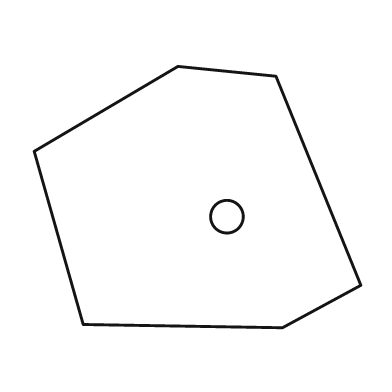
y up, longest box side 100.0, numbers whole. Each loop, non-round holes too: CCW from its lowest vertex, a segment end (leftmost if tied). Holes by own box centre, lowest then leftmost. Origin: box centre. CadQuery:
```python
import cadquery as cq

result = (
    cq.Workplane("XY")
    .moveTo(26.0, -40.0)
    .lineTo(50.0, -27.0)
    .lineTo(24.0, 37.0)
    .lineTo(-6.0, 40.0)
    .lineTo(-50.0, 14.0)
    .lineTo(-35.0, -39.0)
    .close()
    .moveTo(9.0, -6.0)
    .circle(5.0)
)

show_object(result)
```